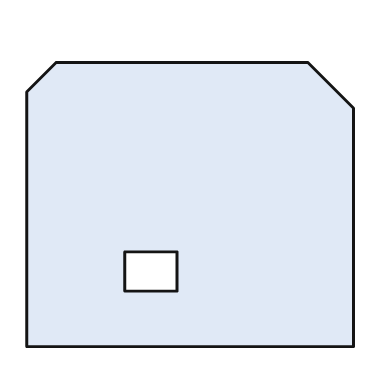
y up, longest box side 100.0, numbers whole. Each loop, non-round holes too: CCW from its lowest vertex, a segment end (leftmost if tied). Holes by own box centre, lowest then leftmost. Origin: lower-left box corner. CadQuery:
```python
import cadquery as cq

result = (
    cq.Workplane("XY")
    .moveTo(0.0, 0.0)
    .lineTo(100.0, 0.0)
    .lineTo(100.0, 73.0)
    .lineTo(86.0, 87.0)
    .lineTo(9.0, 87.0)
    .lineTo(0.0, 78.0)
    .close()
    .moveTo(30.0, 17.0)
    .lineTo(46.0, 17.0)
    .lineTo(46.0, 29.0)
    .lineTo(30.0, 29.0)
    .close()
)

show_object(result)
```